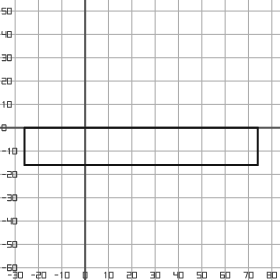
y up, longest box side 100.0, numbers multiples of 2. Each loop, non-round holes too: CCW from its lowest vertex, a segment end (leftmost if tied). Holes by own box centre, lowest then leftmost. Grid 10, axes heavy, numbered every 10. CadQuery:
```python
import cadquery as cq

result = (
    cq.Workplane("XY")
    .moveTo(-26.0, -16.0)
    .lineTo(74.0, -16.0)
    .lineTo(74.0, 0.0)
    .lineTo(-26.0, 0.0)
    .close()
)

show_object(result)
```